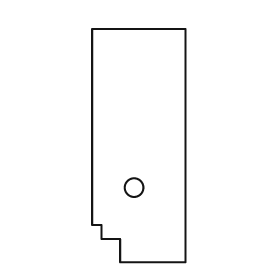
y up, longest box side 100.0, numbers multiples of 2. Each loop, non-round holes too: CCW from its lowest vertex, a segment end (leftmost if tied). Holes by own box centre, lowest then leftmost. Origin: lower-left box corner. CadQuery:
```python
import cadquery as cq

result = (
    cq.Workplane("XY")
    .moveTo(12.0, 0.0)
    .lineTo(40.0, 0.0)
    .lineTo(40.0, 100.0)
    .lineTo(0.0, 100.0)
    .lineTo(0.0, 16.0)
    .lineTo(4.0, 16.0)
    .lineTo(4.0, 10.0)
    .lineTo(12.0, 10.0)
    .close()
    .moveTo(18.0, 32.0)
    .circle(4.0)
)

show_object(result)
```